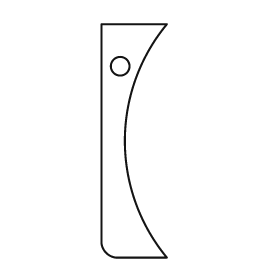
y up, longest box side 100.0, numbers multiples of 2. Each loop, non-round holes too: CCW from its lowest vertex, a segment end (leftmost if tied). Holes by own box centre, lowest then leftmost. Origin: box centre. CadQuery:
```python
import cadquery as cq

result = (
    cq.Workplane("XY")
    .moveTo(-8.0, -50.0)
    .lineTo(14.0, -50.0)
    .threePointArc((-4.0, 0.0), (14.0, 50.0))
    .lineTo(-14.0, 50.0)
    .lineTo(-14.0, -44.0)
    .threePointArc((-12.0, -48.0), (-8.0, -50.0))
    .close()
    .moveTo(-6.0, 32.0)
    .circle(4.0)
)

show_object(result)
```